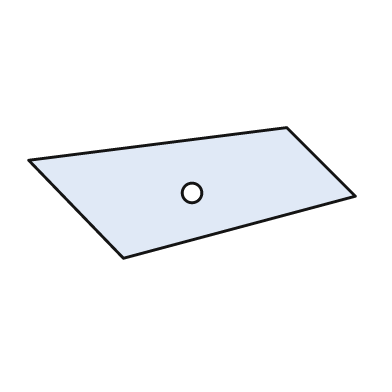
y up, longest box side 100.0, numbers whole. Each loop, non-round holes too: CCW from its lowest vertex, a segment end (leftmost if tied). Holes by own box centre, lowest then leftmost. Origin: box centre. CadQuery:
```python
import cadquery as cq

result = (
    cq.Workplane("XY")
    .moveTo(-21.0, -20.0)
    .lineTo(50.0, -1.0)
    .lineTo(29.0, 20.0)
    .lineTo(-50.0, 10.0)
    .close()
    .moveTo(0.0, 0.0)
    .circle(3.0)
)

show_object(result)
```